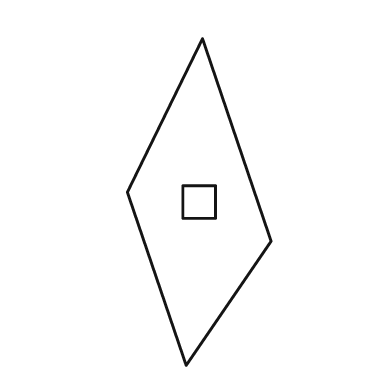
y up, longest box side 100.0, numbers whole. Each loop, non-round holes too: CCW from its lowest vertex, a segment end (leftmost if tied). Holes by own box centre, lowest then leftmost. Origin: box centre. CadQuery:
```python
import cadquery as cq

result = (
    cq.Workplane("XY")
    .moveTo(-4.0, -50.0)
    .lineTo(22.0, -12.0)
    .lineTo(1.0, 50.0)
    .lineTo(-22.0, 3.0)
    .close()
    .moveTo(-5.0, -5.0)
    .lineTo(5.0, -5.0)
    .lineTo(5.0, 5.0)
    .lineTo(-5.0, 5.0)
    .close()
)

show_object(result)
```